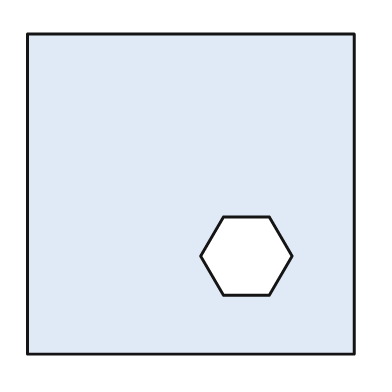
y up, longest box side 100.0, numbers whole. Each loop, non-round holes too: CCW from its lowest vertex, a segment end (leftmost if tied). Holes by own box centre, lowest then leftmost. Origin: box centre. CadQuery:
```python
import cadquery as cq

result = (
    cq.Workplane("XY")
    .moveTo(-50.0, -49.0)
    .lineTo(50.0, -49.0)
    .lineTo(50.0, 49.0)
    .lineTo(-50.0, 49.0)
    .close()
    .moveTo(10.0, -31.0)
    .lineTo(24.0, -31.0)
    .lineTo(31.0, -19.0)
    .lineTo(24.0, -7.0)
    .lineTo(10.0, -7.0)
    .lineTo(3.0, -19.0)
    .close()
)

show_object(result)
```